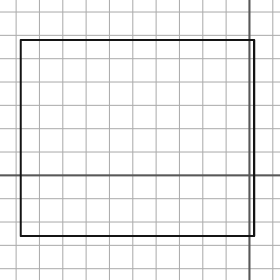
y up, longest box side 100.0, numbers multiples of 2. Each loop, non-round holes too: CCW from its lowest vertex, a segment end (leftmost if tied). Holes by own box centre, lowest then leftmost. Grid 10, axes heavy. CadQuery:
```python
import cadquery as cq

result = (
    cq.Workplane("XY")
    .moveTo(-98.0, -26.0)
    .lineTo(2.0, -26.0)
    .lineTo(2.0, 58.0)
    .lineTo(-98.0, 58.0)
    .close()
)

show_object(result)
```